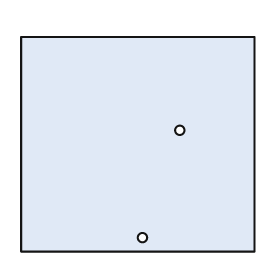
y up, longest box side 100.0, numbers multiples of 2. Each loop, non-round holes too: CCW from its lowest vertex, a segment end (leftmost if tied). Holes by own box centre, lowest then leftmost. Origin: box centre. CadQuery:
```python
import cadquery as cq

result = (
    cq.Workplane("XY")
    .moveTo(-50.0, -46.0)
    .lineTo(50.0, -46.0)
    .lineTo(50.0, 46.0)
    .lineTo(-50.0, 46.0)
    .close()
    .moveTo(2.0, -40.0)
    .circle(2.0)
    .moveTo(18.0, 6.0)
    .circle(2.0)
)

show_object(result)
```